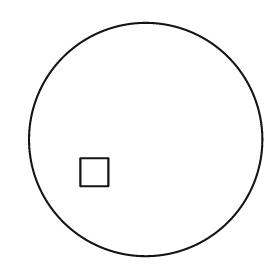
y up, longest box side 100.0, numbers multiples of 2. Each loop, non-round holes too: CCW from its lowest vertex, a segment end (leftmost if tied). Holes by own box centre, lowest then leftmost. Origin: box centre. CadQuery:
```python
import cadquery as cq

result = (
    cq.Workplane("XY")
    .moveTo(0.0, 0.0)
    .circle(50.0)
    .moveTo(-28.0, -20.0)
    .lineTo(-16.0, -20.0)
    .lineTo(-16.0, -8.0)
    .lineTo(-28.0, -8.0)
    .close()
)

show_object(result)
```